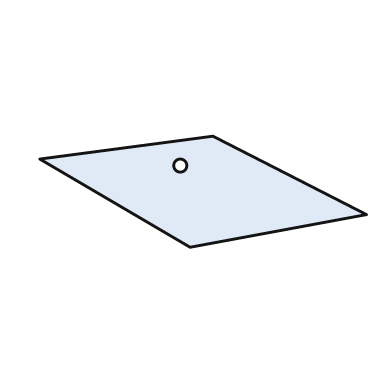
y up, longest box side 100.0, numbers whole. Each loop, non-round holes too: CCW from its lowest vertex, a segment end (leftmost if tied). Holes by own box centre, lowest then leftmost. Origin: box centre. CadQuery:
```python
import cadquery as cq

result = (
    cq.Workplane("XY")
    .moveTo(-4.0, -17.0)
    .lineTo(50.0, -7.0)
    .lineTo(3.0, 17.0)
    .lineTo(-50.0, 10.0)
    .close()
    .moveTo(-7.0, 8.0)
    .circle(2.0)
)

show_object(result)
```